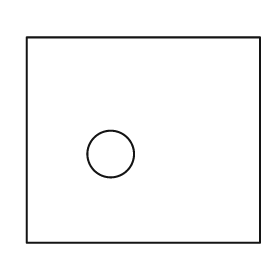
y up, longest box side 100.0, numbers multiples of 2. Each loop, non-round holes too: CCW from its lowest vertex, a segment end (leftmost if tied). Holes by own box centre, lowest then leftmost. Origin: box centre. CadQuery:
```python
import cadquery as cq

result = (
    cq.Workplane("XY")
    .moveTo(-50.0, -44.0)
    .lineTo(50.0, -44.0)
    .lineTo(50.0, 44.0)
    .lineTo(-50.0, 44.0)
    .close()
    .moveTo(-14.0, -6.0)
    .circle(10.0)
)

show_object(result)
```